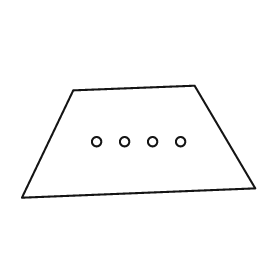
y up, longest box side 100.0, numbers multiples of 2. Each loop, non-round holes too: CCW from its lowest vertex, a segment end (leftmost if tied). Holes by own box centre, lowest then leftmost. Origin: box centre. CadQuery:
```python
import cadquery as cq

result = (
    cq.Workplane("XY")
    .moveTo(-50.0, -24.0)
    .lineTo(50.0, -20.0)
    .lineTo(24.0, 24.0)
    .lineTo(-28.0, 22.0)
    .close()
    .moveTo(-18.0, 0.0)
    .circle(2.0)
    .moveTo(-6.0, 0.0)
    .circle(2.0)
    .moveTo(6.0, 0.0)
    .circle(2.0)
    .moveTo(18.0, 0.0)
    .circle(2.0)
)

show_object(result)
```